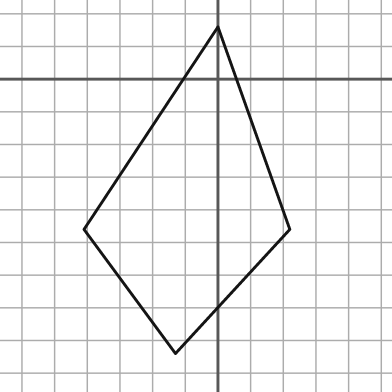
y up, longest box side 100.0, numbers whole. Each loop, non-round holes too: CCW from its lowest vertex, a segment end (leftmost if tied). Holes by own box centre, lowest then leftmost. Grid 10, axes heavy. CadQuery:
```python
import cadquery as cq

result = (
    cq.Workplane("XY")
    .moveTo(-13.0, -84.0)
    .lineTo(22.0, -46.0)
    .lineTo(0.0, 16.0)
    .lineTo(-41.0, -46.0)
    .close()
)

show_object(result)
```